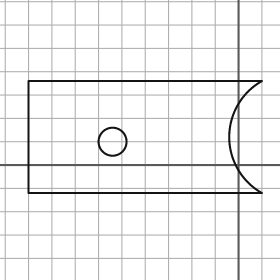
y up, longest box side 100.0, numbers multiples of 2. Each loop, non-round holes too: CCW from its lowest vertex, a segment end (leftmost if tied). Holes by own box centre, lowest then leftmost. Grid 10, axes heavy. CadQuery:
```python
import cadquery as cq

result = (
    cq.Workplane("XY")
    .moveTo(-90.0, -12.0)
    .lineTo(10.0, -12.0)
    .threePointArc((-4.0, 12.0), (10.0, 36.0))
    .lineTo(-90.0, 36.0)
    .close()
    .moveTo(-54.0, 10.0)
    .circle(6.0)
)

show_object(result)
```